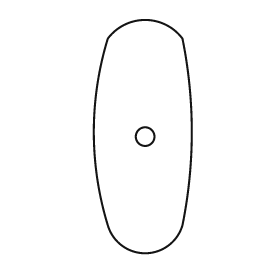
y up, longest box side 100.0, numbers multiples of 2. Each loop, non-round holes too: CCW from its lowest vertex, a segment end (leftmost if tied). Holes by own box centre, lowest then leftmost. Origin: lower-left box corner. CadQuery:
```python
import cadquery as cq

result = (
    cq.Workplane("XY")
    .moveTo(6.0, 12.0)
    .threePointArc((22.0, 0.0), (38.0, 12.0))
    .threePointArc((42.0, 52.0), (38.0, 92.0))
    .threePointArc((22.0, 100.0), (6.0, 92.0))
    .threePointArc((0.0, 52.0), (6.0, 12.0))
    .close()
    .moveTo(22.0, 50.0)
    .circle(4.0)
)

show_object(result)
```